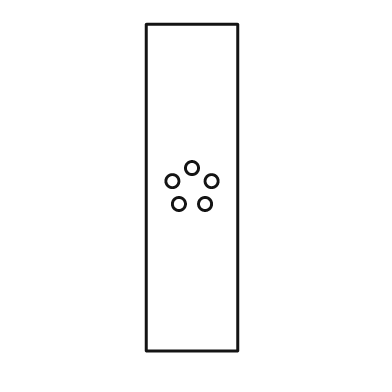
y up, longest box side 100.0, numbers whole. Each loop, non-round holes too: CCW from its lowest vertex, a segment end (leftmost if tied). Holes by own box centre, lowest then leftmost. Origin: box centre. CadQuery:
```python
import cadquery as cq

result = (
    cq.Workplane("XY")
    .moveTo(-14.0, -50.0)
    .lineTo(14.0, -50.0)
    .lineTo(14.0, 50.0)
    .lineTo(-14.0, 50.0)
    .close()
    .moveTo(-4.0, -5.0)
    .circle(2.0)
    .moveTo(4.0, -5.0)
    .circle(2.0)
    .moveTo(-6.0, 2.0)
    .circle(2.0)
    .moveTo(6.0, 2.0)
    .circle(2.0)
    .moveTo(0.0, 6.0)
    .circle(2.0)
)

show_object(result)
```